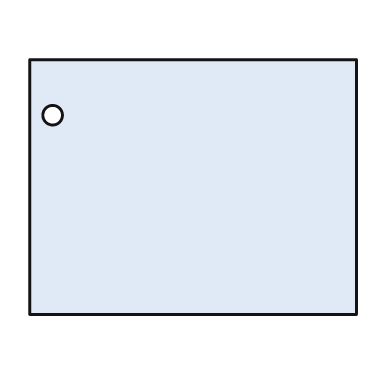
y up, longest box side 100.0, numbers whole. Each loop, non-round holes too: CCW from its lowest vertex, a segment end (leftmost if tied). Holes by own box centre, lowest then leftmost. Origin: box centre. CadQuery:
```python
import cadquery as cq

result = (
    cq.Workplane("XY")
    .moveTo(-50.0, -39.0)
    .lineTo(50.0, -39.0)
    .lineTo(50.0, 39.0)
    .lineTo(-50.0, 39.0)
    .close()
    .moveTo(-43.0, 22.0)
    .circle(3.0)
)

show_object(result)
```